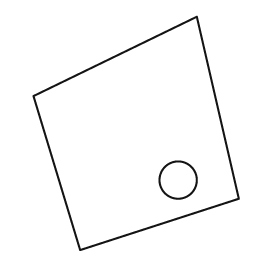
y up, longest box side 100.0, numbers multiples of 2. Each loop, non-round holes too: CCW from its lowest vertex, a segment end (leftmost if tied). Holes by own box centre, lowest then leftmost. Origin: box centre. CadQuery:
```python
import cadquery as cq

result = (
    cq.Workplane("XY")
    .moveTo(-24.0, -50.0)
    .lineTo(44.0, -28.0)
    .lineTo(26.0, 50.0)
    .lineTo(-44.0, 16.0)
    .close()
    .moveTo(18.0, -20.0)
    .circle(8.0)
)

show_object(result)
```